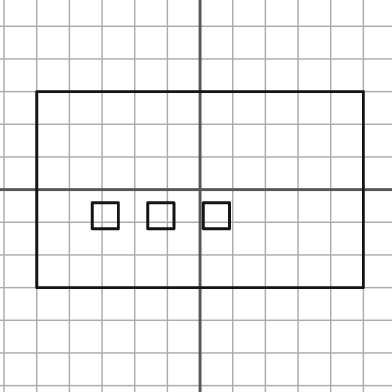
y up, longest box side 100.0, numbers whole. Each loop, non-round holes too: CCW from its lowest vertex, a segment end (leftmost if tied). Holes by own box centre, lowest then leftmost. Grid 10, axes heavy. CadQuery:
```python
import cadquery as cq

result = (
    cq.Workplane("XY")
    .moveTo(-50.0, -30.0)
    .lineTo(50.0, -30.0)
    .lineTo(50.0, 30.0)
    .lineTo(-50.0, 30.0)
    .close()
    .moveTo(-33.0, -12.0)
    .lineTo(-25.0, -12.0)
    .lineTo(-25.0, -4.0)
    .lineTo(-33.0, -4.0)
    .close()
    .moveTo(-16.0, -12.0)
    .lineTo(-8.0, -12.0)
    .lineTo(-8.0, -4.0)
    .lineTo(-16.0, -4.0)
    .close()
    .moveTo(1.0, -12.0)
    .lineTo(9.0, -12.0)
    .lineTo(9.0, -4.0)
    .lineTo(1.0, -4.0)
    .close()
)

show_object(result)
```